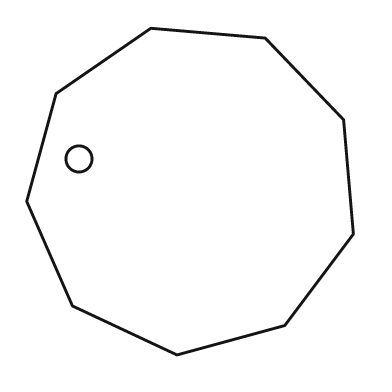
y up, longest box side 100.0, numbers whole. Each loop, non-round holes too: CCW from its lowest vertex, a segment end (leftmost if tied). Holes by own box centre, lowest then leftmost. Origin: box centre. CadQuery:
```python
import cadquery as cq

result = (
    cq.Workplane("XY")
    .moveTo(-4.0, -50.0)
    .lineTo(29.0, -41.0)
    .lineTo(50.0, -13.0)
    .lineTo(47.0, 22.0)
    .lineTo(23.0, 47.0)
    .lineTo(-12.0, 50.0)
    .lineTo(-41.0, 30.0)
    .lineTo(-50.0, -3.0)
    .lineTo(-36.0, -35.0)
    .close()
    .moveTo(-34.0, 10.0)
    .circle(4.0)
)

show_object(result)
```